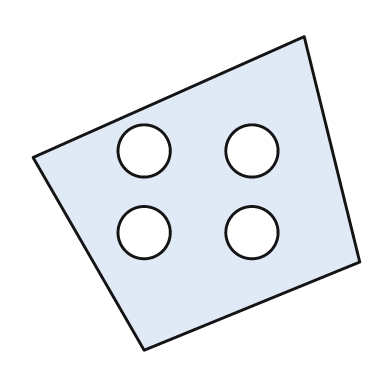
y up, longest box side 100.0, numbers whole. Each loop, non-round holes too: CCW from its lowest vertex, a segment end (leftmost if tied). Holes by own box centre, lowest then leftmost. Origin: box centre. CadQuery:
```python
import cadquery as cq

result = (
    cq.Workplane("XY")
    .moveTo(-16.0, -48.0)
    .lineTo(50.0, -21.0)
    .lineTo(33.0, 48.0)
    .lineTo(-50.0, 11.0)
    .close()
    .moveTo(-16.0, -12.0)
    .circle(8.0)
    .moveTo(17.0, -12.0)
    .circle(8.0)
    .moveTo(-16.0, 13.0)
    .circle(8.0)
    .moveTo(17.0, 13.0)
    .circle(8.0)
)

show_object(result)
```